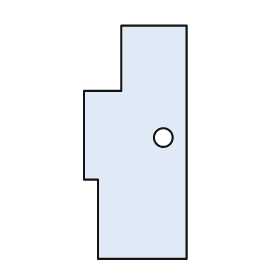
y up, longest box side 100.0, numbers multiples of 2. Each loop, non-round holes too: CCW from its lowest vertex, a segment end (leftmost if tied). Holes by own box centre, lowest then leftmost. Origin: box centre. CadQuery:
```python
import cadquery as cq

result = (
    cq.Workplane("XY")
    .moveTo(-16.0, -50.0)
    .lineTo(22.0, -50.0)
    .lineTo(22.0, 50.0)
    .lineTo(-6.0, 50.0)
    .lineTo(-6.0, 22.0)
    .lineTo(-22.0, 22.0)
    .lineTo(-22.0, -16.0)
    .lineTo(-16.0, -16.0)
    .close()
    .moveTo(12.0, 2.0)
    .circle(4.0)
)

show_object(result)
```